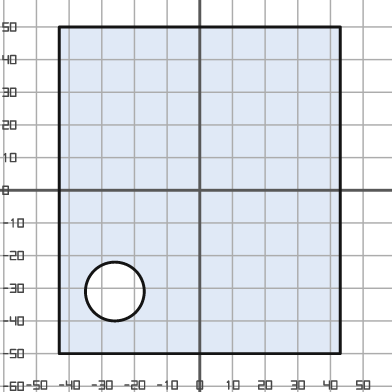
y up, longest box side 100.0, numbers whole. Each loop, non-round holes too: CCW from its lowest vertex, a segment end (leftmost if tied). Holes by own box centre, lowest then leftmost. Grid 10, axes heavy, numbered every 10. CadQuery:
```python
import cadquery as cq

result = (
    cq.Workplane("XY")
    .moveTo(-43.0, -50.0)
    .lineTo(43.0, -50.0)
    .lineTo(43.0, 50.0)
    .lineTo(-43.0, 50.0)
    .close()
    .moveTo(-26.0, -31.0)
    .circle(9.0)
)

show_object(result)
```